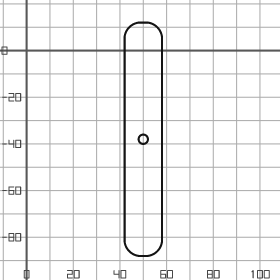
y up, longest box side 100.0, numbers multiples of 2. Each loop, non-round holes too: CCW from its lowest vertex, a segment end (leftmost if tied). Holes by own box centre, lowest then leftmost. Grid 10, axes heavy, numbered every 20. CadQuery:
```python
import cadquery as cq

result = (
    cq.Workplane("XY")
    .moveTo(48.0, -88.0)
    .lineTo(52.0, -88.0)
    .threePointArc((56.0, -86.0), (58.0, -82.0))
    .lineTo(58.0, 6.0)
    .threePointArc((56.0, 10.0), (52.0, 12.0))
    .lineTo(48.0, 12.0)
    .threePointArc((44.0, 10.0), (42.0, 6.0))
    .lineTo(42.0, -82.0)
    .threePointArc((44.0, -86.0), (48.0, -88.0))
    .close()
    .moveTo(50.0, -38.0)
    .circle(2.0)
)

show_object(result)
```